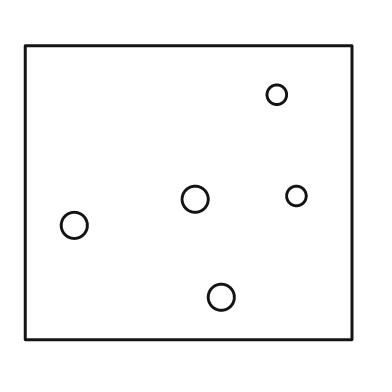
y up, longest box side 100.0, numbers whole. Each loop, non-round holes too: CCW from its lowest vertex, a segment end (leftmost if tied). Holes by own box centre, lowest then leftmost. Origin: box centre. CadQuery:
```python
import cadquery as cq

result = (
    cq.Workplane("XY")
    .moveTo(-50.0, -45.0)
    .lineTo(50.0, -45.0)
    .lineTo(50.0, 45.0)
    .lineTo(-50.0, 45.0)
    .close()
    .moveTo(10.0, -32.0)
    .circle(4.0)
    .moveTo(-35.0, -10.0)
    .circle(4.0)
    .moveTo(2.0, -2.0)
    .circle(4.0)
    .moveTo(33.0, -1.0)
    .circle(3.0)
    .moveTo(27.0, 30.0)
    .circle(3.0)
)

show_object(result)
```